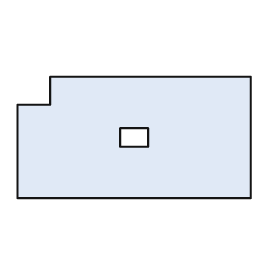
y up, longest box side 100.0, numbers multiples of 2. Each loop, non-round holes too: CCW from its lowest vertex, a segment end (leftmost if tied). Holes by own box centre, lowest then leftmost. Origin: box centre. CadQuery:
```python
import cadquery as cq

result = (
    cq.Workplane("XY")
    .moveTo(-50.0, -26.0)
    .lineTo(50.0, -26.0)
    .lineTo(50.0, 26.0)
    .lineTo(-36.0, 26.0)
    .lineTo(-36.0, 14.0)
    .lineTo(-50.0, 14.0)
    .close()
    .moveTo(-6.0, -4.0)
    .lineTo(6.0, -4.0)
    .lineTo(6.0, 4.0)
    .lineTo(-6.0, 4.0)
    .close()
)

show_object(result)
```